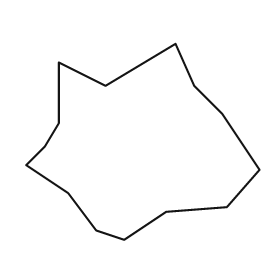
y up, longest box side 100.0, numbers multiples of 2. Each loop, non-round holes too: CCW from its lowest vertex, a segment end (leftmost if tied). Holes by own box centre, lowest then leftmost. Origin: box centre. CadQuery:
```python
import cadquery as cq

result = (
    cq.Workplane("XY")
    .moveTo(-8.0, -42.0)
    .lineTo(10.0, -30.0)
    .lineTo(36.0, -28.0)
    .lineTo(50.0, -12.0)
    .lineTo(34.0, 12.0)
    .lineTo(22.0, 24.0)
    .lineTo(14.0, 42.0)
    .lineTo(-16.0, 24.0)
    .lineTo(-36.0, 34.0)
    .lineTo(-36.0, 8.0)
    .lineTo(-42.0, -2.0)
    .lineTo(-50.0, -10.0)
    .lineTo(-32.0, -22.0)
    .lineTo(-20.0, -38.0)
    .close()
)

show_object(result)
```